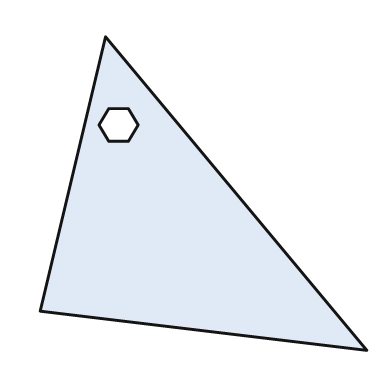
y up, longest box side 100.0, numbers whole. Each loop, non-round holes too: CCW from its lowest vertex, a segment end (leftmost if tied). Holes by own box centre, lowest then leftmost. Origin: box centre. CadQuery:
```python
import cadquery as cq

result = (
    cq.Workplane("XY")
    .moveTo(50.0, -48.0)
    .lineTo(-30.0, 48.0)
    .lineTo(-50.0, -36.0)
    .close()
    .moveTo(-29.0, 16.0)
    .lineTo(-23.0, 16.0)
    .lineTo(-20.0, 21.0)
    .lineTo(-23.0, 26.0)
    .lineTo(-29.0, 26.0)
    .lineTo(-32.0, 21.0)
    .close()
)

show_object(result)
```